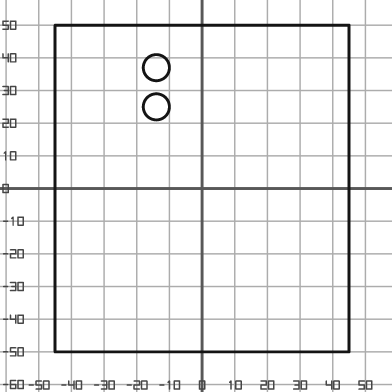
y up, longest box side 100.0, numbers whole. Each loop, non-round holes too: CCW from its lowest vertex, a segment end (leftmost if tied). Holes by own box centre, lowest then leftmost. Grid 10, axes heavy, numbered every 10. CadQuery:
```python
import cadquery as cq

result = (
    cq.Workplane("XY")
    .moveTo(-45.0, -50.0)
    .lineTo(45.0, -50.0)
    .lineTo(45.0, 50.0)
    .lineTo(-45.0, 50.0)
    .close()
    .moveTo(-14.0, 25.0)
    .circle(4.0)
    .moveTo(-14.0, 37.0)
    .circle(4.0)
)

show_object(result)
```